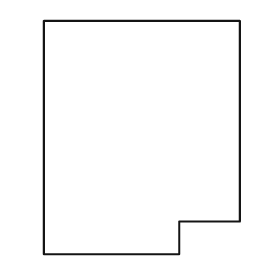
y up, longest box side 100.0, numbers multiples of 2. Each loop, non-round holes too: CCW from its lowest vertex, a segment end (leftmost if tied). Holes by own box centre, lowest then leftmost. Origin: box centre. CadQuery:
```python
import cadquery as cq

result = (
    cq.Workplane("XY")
    .moveTo(-42.0, -50.0)
    .lineTo(16.0, -50.0)
    .lineTo(16.0, -36.0)
    .lineTo(42.0, -36.0)
    .lineTo(42.0, 50.0)
    .lineTo(-42.0, 50.0)
    .close()
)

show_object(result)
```